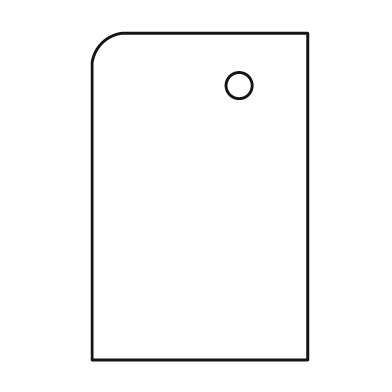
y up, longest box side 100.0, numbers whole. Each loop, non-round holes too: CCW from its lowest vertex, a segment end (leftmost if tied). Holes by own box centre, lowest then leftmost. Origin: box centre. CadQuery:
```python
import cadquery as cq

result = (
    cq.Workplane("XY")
    .moveTo(-33.0, -50.0)
    .lineTo(33.0, -50.0)
    .lineTo(33.0, 50.0)
    .lineTo(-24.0, 50.0)
    .threePointArc((-30.0, 47.0), (-33.0, 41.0))
    .close()
    .moveTo(12.0, 34.0)
    .circle(4.0)
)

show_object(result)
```